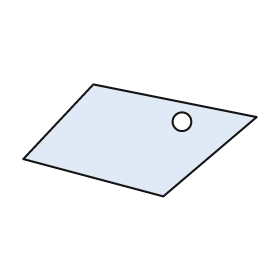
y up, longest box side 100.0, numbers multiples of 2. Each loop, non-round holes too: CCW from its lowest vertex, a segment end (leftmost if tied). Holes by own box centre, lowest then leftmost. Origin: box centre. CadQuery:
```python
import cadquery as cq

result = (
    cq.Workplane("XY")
    .moveTo(10.0, -24.0)
    .lineTo(50.0, 10.0)
    .lineTo(-20.0, 24.0)
    .lineTo(-50.0, -8.0)
    .close()
    .moveTo(18.0, 8.0)
    .circle(4.0)
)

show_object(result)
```